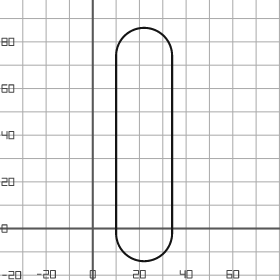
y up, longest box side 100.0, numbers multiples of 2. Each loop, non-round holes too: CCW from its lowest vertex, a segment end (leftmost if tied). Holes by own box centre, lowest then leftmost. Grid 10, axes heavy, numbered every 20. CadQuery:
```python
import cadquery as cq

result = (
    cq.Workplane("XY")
    .moveTo(10.0, -2.0)
    .threePointArc((22.0, -14.0), (34.0, -2.0))
    .lineTo(34.0, 74.0)
    .threePointArc((22.0, 86.0), (10.0, 74.0))
    .close()
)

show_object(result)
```